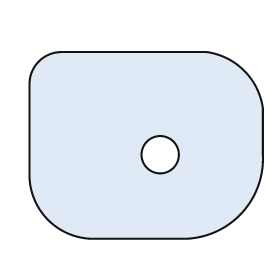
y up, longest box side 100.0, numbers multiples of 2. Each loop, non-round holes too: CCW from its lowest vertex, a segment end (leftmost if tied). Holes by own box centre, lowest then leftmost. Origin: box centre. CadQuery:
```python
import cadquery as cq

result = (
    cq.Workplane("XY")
    .moveTo(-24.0, -40.0)
    .lineTo(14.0, -40.0)
    .threePointArc((40.0, -30.0), (50.0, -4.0))
    .lineTo(50.0, 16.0)
    .threePointArc((42.0, 32.0), (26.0, 40.0))
    .lineTo(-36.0, 40.0)
    .threePointArc((-46.0, 36.0), (-50.0, 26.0))
    .lineTo(-50.0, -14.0)
    .threePointArc((-42.0, -32.0), (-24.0, -40.0))
    .close()
    .moveTo(6.0, -4.0)
    .circle(8.0)
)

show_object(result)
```